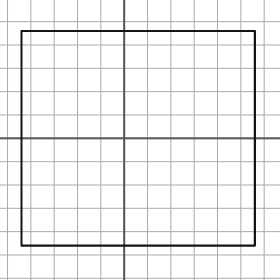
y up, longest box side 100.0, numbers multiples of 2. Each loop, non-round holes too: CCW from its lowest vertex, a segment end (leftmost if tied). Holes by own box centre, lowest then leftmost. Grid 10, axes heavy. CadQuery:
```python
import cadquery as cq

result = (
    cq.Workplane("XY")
    .moveTo(-44.0, -46.0)
    .lineTo(56.0, -46.0)
    .lineTo(56.0, 46.0)
    .lineTo(-44.0, 46.0)
    .close()
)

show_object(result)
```